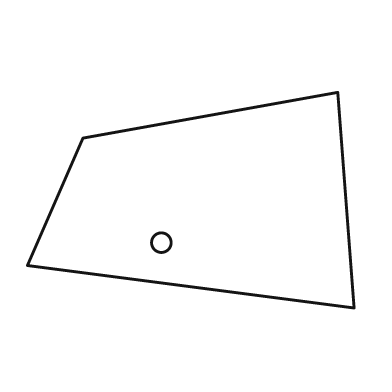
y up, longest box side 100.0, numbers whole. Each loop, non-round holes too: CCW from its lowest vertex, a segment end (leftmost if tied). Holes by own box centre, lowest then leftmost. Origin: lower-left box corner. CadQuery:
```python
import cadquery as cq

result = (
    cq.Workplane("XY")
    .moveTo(100.0, 0.0)
    .lineTo(95.0, 66.0)
    .lineTo(17.0, 52.0)
    .lineTo(0.0, 13.0)
    .close()
    .moveTo(41.0, 20.0)
    .circle(3.0)
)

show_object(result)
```